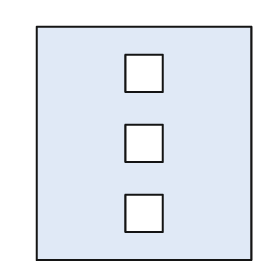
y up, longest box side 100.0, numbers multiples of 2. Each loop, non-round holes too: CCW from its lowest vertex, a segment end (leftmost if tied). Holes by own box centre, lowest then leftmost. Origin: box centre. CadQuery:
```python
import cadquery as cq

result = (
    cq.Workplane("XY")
    .moveTo(-46.0, -50.0)
    .lineTo(46.0, -50.0)
    .lineTo(46.0, 50.0)
    .lineTo(-46.0, 50.0)
    .close()
    .moveTo(-8.0, -38.0)
    .lineTo(8.0, -38.0)
    .lineTo(8.0, -22.0)
    .lineTo(-8.0, -22.0)
    .close()
    .moveTo(-8.0, -8.0)
    .lineTo(8.0, -8.0)
    .lineTo(8.0, 8.0)
    .lineTo(-8.0, 8.0)
    .close()
    .moveTo(-8.0, 22.0)
    .lineTo(8.0, 22.0)
    .lineTo(8.0, 38.0)
    .lineTo(-8.0, 38.0)
    .close()
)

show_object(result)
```